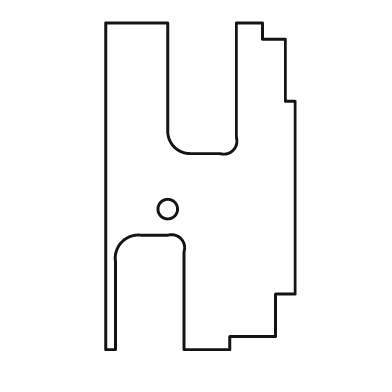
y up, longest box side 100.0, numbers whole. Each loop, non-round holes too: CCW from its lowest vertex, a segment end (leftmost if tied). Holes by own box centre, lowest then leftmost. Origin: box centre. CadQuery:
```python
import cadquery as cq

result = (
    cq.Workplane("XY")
    .moveTo(-29.0, -50.0)
    .lineTo(-26.0, -50.0)
    .lineTo(-26.0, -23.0)
    .threePointArc((-24.0, -17.0), (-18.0, -15.0))
    .lineTo(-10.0, -15.0)
    .threePointArc((-6.0, -16.0), (-5.0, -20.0))
    .lineTo(-5.0, -50.0)
    .lineTo(9.0, -50.0)
    .lineTo(9.0, -46.0)
    .lineTo(23.0, -46.0)
    .lineTo(23.0, -33.0)
    .lineTo(29.0, -33.0)
    .lineTo(29.0, 26.0)
    .lineTo(26.0, 26.0)
    .lineTo(26.0, 45.0)
    .lineTo(19.0, 45.0)
    .lineTo(19.0, 50.0)
    .lineTo(11.0, 50.0)
    .lineTo(11.0, 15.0)
    .threePointArc((10.0, 11.0), (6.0, 10.0))
    .lineTo(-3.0, 10.0)
    .threePointArc((-8.0, 12.0), (-10.0, 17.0))
    .lineTo(-10.0, 50.0)
    .lineTo(-29.0, 50.0)
    .close()
    .moveTo(-10.0, -7.0)
    .circle(3.0)
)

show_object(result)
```